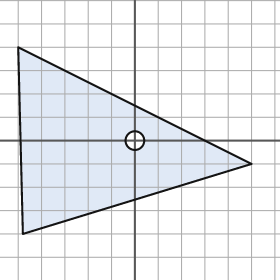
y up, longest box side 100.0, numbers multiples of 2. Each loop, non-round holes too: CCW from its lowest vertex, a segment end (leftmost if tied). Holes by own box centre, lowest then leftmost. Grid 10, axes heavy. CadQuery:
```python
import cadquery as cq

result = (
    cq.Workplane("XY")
    .moveTo(-48.0, -40.0)
    .lineTo(50.0, -10.0)
    .lineTo(-50.0, 40.0)
    .close()
    .moveTo(0.0, 0.0)
    .circle(4.0)
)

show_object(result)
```